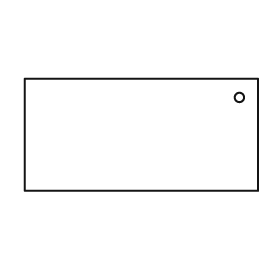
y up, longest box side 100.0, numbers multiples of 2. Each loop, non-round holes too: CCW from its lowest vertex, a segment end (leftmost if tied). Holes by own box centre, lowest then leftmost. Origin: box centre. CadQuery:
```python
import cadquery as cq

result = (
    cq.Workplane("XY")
    .moveTo(-50.0, -24.0)
    .lineTo(50.0, -24.0)
    .lineTo(50.0, 24.0)
    .lineTo(-50.0, 24.0)
    .close()
    .moveTo(42.0, 16.0)
    .circle(2.0)
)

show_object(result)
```